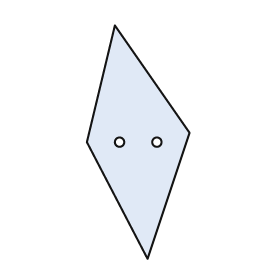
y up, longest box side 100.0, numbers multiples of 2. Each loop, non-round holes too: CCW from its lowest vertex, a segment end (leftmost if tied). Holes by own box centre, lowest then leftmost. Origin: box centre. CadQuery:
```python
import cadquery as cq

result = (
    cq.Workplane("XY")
    .moveTo(4.0, -50.0)
    .lineTo(22.0, 4.0)
    .lineTo(-10.0, 50.0)
    .lineTo(-22.0, 0.0)
    .close()
    .moveTo(-8.0, 0.0)
    .circle(2.0)
    .moveTo(8.0, 0.0)
    .circle(2.0)
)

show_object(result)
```